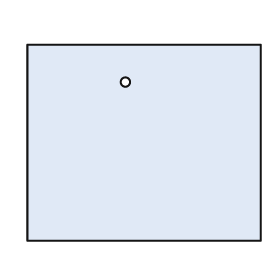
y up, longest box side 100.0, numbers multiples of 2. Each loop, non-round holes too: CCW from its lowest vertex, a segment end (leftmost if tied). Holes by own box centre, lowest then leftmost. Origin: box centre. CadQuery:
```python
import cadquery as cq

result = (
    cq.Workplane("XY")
    .moveTo(-50.0, -42.0)
    .lineTo(50.0, -42.0)
    .lineTo(50.0, 42.0)
    .lineTo(-50.0, 42.0)
    .close()
    .moveTo(-8.0, 26.0)
    .circle(2.0)
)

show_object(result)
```